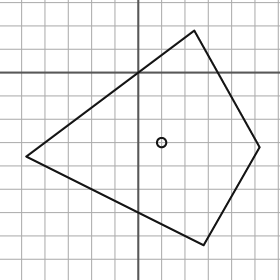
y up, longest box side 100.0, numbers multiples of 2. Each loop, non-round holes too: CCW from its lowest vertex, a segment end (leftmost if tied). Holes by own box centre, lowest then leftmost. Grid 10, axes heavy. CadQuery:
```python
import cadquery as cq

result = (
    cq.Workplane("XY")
    .moveTo(28.0, -74.0)
    .lineTo(52.0, -32.0)
    .lineTo(24.0, 18.0)
    .lineTo(-48.0, -36.0)
    .close()
    .moveTo(10.0, -30.0)
    .circle(2.0)
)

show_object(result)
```